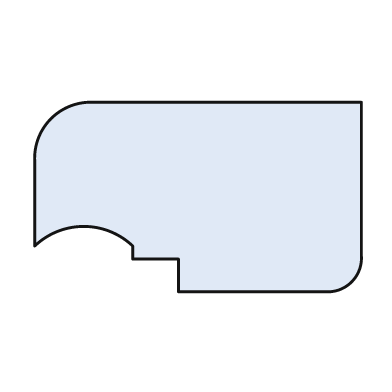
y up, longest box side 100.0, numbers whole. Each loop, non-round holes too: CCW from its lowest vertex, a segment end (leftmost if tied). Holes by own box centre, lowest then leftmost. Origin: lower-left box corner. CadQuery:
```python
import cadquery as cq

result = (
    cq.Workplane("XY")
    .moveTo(44.0, 0.0)
    .lineTo(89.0, 0.0)
    .threePointArc((97.0, 3.0), (100.0, 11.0))
    .lineTo(100.0, 58.0)
    .lineTo(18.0, 58.0)
    .threePointArc((5.0, 53.0), (0.0, 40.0))
    .lineTo(0.0, 14.0)
    .threePointArc((15.0, 20.0), (30.0, 14.0))
    .lineTo(30.0, 10.0)
    .lineTo(44.0, 10.0)
    .close()
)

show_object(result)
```